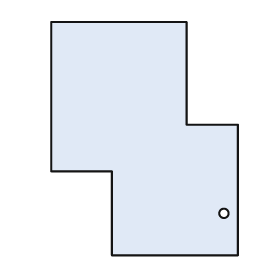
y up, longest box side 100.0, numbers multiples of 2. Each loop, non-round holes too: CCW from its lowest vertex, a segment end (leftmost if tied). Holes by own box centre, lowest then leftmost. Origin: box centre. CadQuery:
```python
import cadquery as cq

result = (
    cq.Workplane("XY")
    .moveTo(-14.0, -50.0)
    .lineTo(40.0, -50.0)
    .lineTo(40.0, 6.0)
    .lineTo(18.0, 6.0)
    .lineTo(18.0, 50.0)
    .lineTo(-40.0, 50.0)
    .lineTo(-40.0, -14.0)
    .lineTo(-14.0, -14.0)
    .close()
    .moveTo(34.0, -32.0)
    .circle(2.0)
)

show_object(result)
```